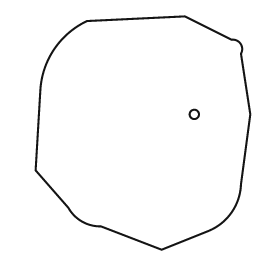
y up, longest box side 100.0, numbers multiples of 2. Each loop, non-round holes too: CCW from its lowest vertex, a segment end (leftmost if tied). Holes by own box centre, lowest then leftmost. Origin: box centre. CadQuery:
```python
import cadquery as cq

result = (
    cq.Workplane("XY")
    .moveTo(8.0, -50.0)
    .lineTo(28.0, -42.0)
    .threePointArc((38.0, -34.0), (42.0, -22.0))
    .lineTo(46.0, 8.0)
    .lineTo(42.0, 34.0)
    .threePointArc((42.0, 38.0), (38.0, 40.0))
    .lineTo(18.0, 50.0)
    .lineTo(-24.0, 48.0)
    .threePointArc((-38.0, 36.0), (-44.0, 18.0))
    .lineTo(-46.0, -16.0)
    .lineTo(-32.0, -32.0)
    .threePointArc((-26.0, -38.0), (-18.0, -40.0))
    .close()
    .moveTo(22.0, 8.0)
    .circle(2.0)
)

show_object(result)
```